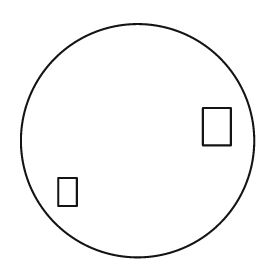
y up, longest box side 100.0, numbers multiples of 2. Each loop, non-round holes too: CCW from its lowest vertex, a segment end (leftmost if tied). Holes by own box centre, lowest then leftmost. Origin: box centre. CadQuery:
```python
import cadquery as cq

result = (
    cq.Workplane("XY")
    .moveTo(0.0, 0.0)
    .circle(50.0)
    .moveTo(-34.0, -28.0)
    .lineTo(-26.0, -28.0)
    .lineTo(-26.0, -16.0)
    .lineTo(-34.0, -16.0)
    .close()
    .moveTo(28.0, -2.0)
    .lineTo(40.0, -2.0)
    .lineTo(40.0, 14.0)
    .lineTo(28.0, 14.0)
    .close()
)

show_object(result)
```